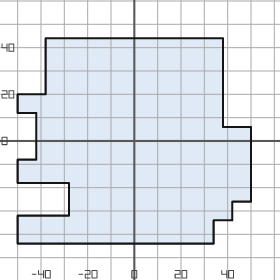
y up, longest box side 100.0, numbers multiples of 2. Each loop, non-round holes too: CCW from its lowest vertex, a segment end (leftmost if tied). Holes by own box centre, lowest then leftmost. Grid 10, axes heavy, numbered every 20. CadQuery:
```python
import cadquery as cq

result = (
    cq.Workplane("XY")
    .moveTo(-50.0, -44.0)
    .lineTo(34.0, -44.0)
    .lineTo(34.0, -34.0)
    .lineTo(42.0, -34.0)
    .lineTo(42.0, -26.0)
    .lineTo(50.0, -26.0)
    .lineTo(50.0, 6.0)
    .lineTo(38.0, 6.0)
    .lineTo(38.0, 44.0)
    .lineTo(-38.0, 44.0)
    .lineTo(-38.0, 20.0)
    .lineTo(-50.0, 20.0)
    .lineTo(-50.0, 12.0)
    .lineTo(-42.0, 12.0)
    .lineTo(-42.0, -8.0)
    .lineTo(-50.0, -8.0)
    .lineTo(-50.0, -18.0)
    .lineTo(-28.0, -18.0)
    .lineTo(-28.0, -32.0)
    .lineTo(-50.0, -32.0)
    .close()
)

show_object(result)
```